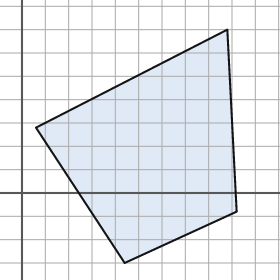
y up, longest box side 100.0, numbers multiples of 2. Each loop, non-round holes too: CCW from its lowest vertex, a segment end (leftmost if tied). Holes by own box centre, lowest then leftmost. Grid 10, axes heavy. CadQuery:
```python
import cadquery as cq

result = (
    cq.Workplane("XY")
    .moveTo(44.0, -30.0)
    .lineTo(92.0, -8.0)
    .lineTo(88.0, 70.0)
    .lineTo(6.0, 28.0)
    .close()
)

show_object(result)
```